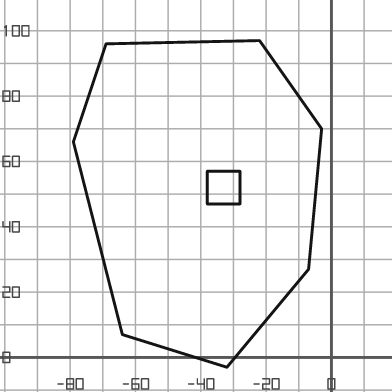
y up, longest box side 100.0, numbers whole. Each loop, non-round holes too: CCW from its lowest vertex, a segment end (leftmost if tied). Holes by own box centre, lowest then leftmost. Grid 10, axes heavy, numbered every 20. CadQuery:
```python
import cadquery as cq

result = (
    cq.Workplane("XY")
    .moveTo(-32.0, -3.0)
    .lineTo(-7.0, 27.0)
    .lineTo(-3.0, 70.0)
    .lineTo(-22.0, 97.0)
    .lineTo(-69.0, 96.0)
    .lineTo(-79.0, 66.0)
    .lineTo(-64.0, 7.0)
    .close()
    .moveTo(-38.0, 47.0)
    .lineTo(-28.0, 47.0)
    .lineTo(-28.0, 57.0)
    .lineTo(-38.0, 57.0)
    .close()
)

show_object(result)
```